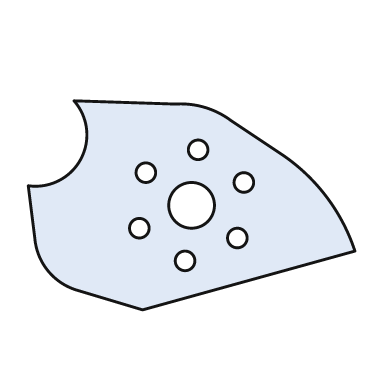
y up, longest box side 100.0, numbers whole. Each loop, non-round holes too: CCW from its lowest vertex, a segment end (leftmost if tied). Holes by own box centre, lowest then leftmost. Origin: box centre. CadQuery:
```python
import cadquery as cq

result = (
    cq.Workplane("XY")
    .moveTo(-15.0, -32.0)
    .lineTo(50.0, -14.0)
    .threePointArc((41.0, 3.0), (27.0, 16.0))
    .lineTo(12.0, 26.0)
    .threePointArc((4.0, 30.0), (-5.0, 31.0))
    .lineTo(-36.0, 32.0)
    .threePointArc((-34.0, 14.0), (-50.0, 6.0))
    .lineTo(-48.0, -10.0)
    .threePointArc((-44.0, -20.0), (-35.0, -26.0))
    .close()
    .moveTo(-2.0, -17.0)
    .circle(3.0)
    .moveTo(14.0, -10.0)
    .circle(3.0)
    .moveTo(-16.0, -7.0)
    .circle(3.0)
    .moveTo(0.0, 0.0)
    .circle(7.0)
    .moveTo(16.0, 7.0)
    .circle(3.0)
    .moveTo(-14.0, 10.0)
    .circle(3.0)
    .moveTo(2.0, 17.0)
    .circle(3.0)
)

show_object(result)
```